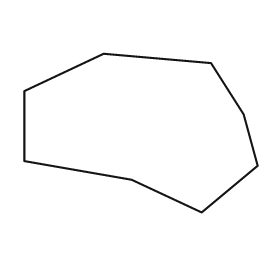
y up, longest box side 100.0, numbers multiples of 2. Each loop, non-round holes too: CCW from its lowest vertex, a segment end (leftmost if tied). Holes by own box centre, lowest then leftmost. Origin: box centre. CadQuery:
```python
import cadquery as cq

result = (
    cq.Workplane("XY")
    .moveTo(26.0, -34.0)
    .lineTo(50.0, -14.0)
    .lineTo(44.0, 8.0)
    .lineTo(30.0, 30.0)
    .lineTo(-16.0, 34.0)
    .lineTo(-50.0, 18.0)
    .lineTo(-50.0, -12.0)
    .lineTo(-4.0, -20.0)
    .close()
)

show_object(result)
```